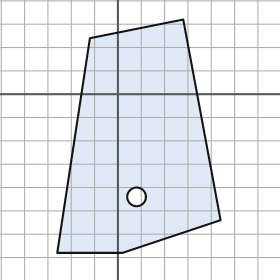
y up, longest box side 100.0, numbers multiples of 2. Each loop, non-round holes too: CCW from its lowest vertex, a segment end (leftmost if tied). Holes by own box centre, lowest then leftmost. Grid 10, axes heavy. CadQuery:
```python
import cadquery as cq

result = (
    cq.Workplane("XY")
    .moveTo(-26.0, -68.0)
    .lineTo(2.0, -68.0)
    .lineTo(44.0, -54.0)
    .lineTo(28.0, 32.0)
    .lineTo(-12.0, 24.0)
    .close()
    .moveTo(8.0, -44.0)
    .circle(4.0)
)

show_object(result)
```